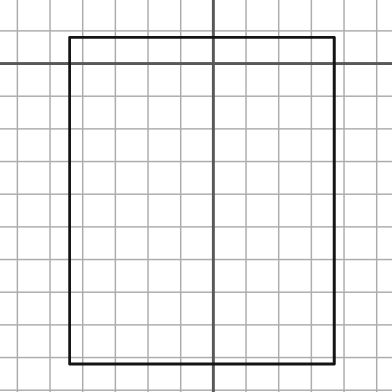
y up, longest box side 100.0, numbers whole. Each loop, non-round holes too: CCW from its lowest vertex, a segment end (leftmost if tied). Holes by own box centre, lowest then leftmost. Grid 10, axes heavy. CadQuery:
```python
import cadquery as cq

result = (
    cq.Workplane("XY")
    .moveTo(-44.0, -92.0)
    .lineTo(37.0, -92.0)
    .lineTo(37.0, 8.0)
    .lineTo(-44.0, 8.0)
    .close()
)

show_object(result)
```